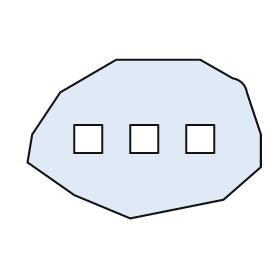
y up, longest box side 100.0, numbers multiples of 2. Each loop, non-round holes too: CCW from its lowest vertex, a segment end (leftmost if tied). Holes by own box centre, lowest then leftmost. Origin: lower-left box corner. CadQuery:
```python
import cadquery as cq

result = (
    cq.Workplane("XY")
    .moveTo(44.0, 0.0)
    .lineTo(84.0, 8.0)
    .lineTo(100.0, 22.0)
    .lineTo(100.0, 36.0)
    .lineTo(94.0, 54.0)
    .threePointArc((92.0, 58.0), (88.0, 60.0))
    .lineTo(74.0, 68.0)
    .lineTo(38.0, 68.0)
    .lineTo(14.0, 54.0)
    .lineTo(2.0, 36.0)
    .lineTo(0.0, 24.0)
    .lineTo(20.0, 10.0)
    .close()
    .moveTo(20.0, 28.0)
    .lineTo(32.0, 28.0)
    .lineTo(32.0, 40.0)
    .lineTo(20.0, 40.0)
    .close()
    .moveTo(44.0, 28.0)
    .lineTo(56.0, 28.0)
    .lineTo(56.0, 40.0)
    .lineTo(44.0, 40.0)
    .close()
    .moveTo(68.0, 28.0)
    .lineTo(80.0, 28.0)
    .lineTo(80.0, 40.0)
    .lineTo(68.0, 40.0)
    .close()
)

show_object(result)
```